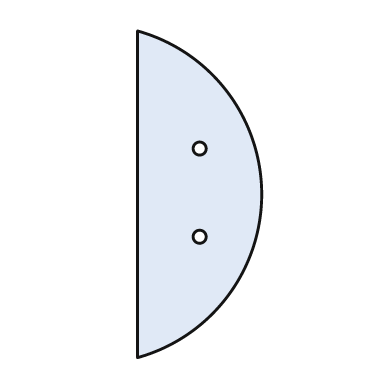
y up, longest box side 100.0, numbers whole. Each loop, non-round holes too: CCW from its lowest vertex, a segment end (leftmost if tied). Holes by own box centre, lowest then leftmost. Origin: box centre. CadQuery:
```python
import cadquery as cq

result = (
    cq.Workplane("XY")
    .moveTo(-19.0, -50.0)
    .threePointArc((19.0, 0.0), (-19.0, 50.0))
    .close()
    .moveTo(0.0, -13.0)
    .circle(2.0)
    .moveTo(0.0, 14.0)
    .circle(2.0)
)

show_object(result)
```